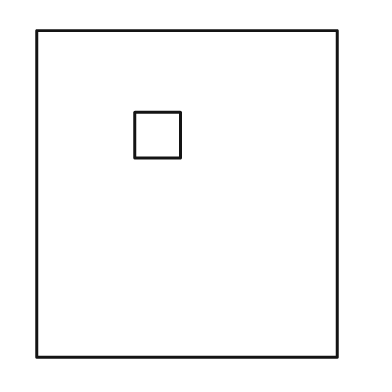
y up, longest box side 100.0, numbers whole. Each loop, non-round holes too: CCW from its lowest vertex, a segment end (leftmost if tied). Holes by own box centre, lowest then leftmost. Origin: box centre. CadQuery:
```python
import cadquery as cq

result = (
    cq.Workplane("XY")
    .moveTo(-46.0, -50.0)
    .lineTo(46.0, -50.0)
    .lineTo(46.0, 50.0)
    .lineTo(-46.0, 50.0)
    .close()
    .moveTo(-16.0, 11.0)
    .lineTo(-2.0, 11.0)
    .lineTo(-2.0, 25.0)
    .lineTo(-16.0, 25.0)
    .close()
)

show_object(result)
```